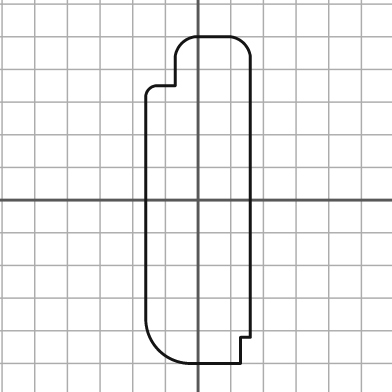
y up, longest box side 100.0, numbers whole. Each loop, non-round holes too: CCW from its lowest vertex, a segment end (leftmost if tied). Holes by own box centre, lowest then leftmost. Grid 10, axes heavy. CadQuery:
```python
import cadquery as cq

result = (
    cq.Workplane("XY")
    .moveTo(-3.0, -50.0)
    .lineTo(13.0, -50.0)
    .lineTo(13.0, -42.0)
    .lineTo(16.0, -42.0)
    .lineTo(16.0, 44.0)
    .threePointArc((14.0, 48.0), (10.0, 50.0))
    .lineTo(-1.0, 50.0)
    .threePointArc((-5.0, 48.0), (-7.0, 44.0))
    .lineTo(-7.0, 35.0)
    .lineTo(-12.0, 35.0)
    .threePointArc((-15.0, 34.0), (-16.0, 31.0))
    .lineTo(-16.0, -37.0)
    .threePointArc((-12.0, -46.0), (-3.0, -50.0))
    .close()
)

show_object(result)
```